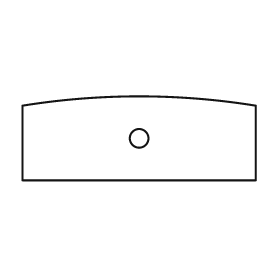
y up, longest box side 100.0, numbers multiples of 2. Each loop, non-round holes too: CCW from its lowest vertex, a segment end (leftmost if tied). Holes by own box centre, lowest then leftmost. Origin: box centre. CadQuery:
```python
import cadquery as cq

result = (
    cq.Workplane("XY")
    .moveTo(-50.0, -18.0)
    .lineTo(50.0, -18.0)
    .lineTo(50.0, 14.0)
    .threePointArc((0.0, 18.0), (-50.0, 14.0))
    .close()
    .moveTo(0.0, 0.0)
    .circle(4.0)
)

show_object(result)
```